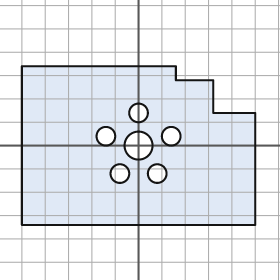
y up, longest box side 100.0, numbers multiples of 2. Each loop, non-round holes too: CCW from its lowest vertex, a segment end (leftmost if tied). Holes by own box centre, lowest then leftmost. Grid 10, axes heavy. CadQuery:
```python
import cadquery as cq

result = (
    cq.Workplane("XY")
    .moveTo(-50.0, -34.0)
    .lineTo(50.0, -34.0)
    .lineTo(50.0, 14.0)
    .lineTo(32.0, 14.0)
    .lineTo(32.0, 28.0)
    .lineTo(16.0, 28.0)
    .lineTo(16.0, 34.0)
    .lineTo(-50.0, 34.0)
    .close()
    .moveTo(-8.0, -12.0)
    .circle(4.0)
    .moveTo(8.0, -12.0)
    .circle(4.0)
    .moveTo(0.0, 0.0)
    .circle(6.0)
    .moveTo(-14.0, 4.0)
    .circle(4.0)
    .moveTo(14.0, 4.0)
    .circle(4.0)
    .moveTo(0.0, 14.0)
    .circle(4.0)
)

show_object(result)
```